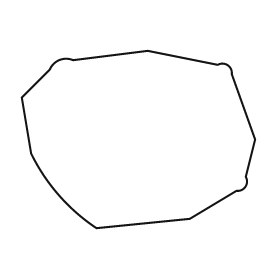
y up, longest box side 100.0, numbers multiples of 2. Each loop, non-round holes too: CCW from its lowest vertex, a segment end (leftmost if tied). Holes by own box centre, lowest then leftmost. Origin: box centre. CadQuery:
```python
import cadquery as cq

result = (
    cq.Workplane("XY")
    .moveTo(-18.0, -38.0)
    .lineTo(22.0, -34.0)
    .lineTo(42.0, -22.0)
    .threePointArc((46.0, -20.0), (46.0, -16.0))
    .lineTo(50.0, 0.0)
    .lineTo(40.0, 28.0)
    .threePointArc((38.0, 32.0), (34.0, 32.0))
    .lineTo(4.0, 38.0)
    .lineTo(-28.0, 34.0)
    .threePointArc((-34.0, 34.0), (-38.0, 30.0))
    .lineTo(-50.0, 18.0)
    .lineTo(-46.0, -6.0)
    .threePointArc((-34.0, -24.0), (-18.0, -38.0))
    .close()
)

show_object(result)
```